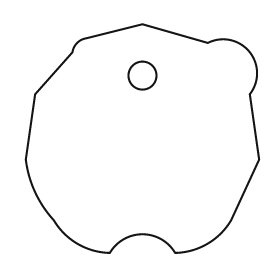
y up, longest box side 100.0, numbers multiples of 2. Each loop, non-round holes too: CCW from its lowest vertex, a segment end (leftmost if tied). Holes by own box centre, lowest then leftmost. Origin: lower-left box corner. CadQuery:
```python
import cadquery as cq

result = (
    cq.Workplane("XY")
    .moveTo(36.0, 0.0)
    .threePointArc((50.0, 8.0), (64.0, 0.0))
    .threePointArc((78.0, 4.0), (88.0, 14.0))
    .lineTo(100.0, 40.0)
    .lineTo(96.0, 68.0)
    .threePointArc((96.0, 86.0), (78.0, 90.0))
    .lineTo(50.0, 98.0)
    .lineTo(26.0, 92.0)
    .threePointArc((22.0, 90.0), (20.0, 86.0))
    .lineTo(4.0, 68.0)
    .lineTo(0.0, 40.0)
    .threePointArc((4.0, 26.0), (12.0, 14.0))
    .threePointArc((22.0, 4.0), (36.0, 0.0))
    .close()
    .moveTo(50.0, 76.0)
    .circle(6.0)
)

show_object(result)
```